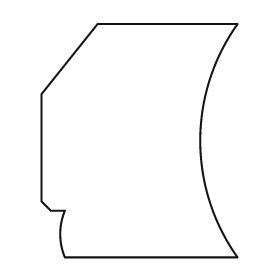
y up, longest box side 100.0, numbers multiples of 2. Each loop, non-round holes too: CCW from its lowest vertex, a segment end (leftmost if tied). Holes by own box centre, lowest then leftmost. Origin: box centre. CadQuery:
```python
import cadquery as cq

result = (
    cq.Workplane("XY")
    .moveTo(-32.0, -50.0)
    .lineTo(42.0, -50.0)
    .threePointArc((26.0, 0.0), (42.0, 50.0))
    .lineTo(-18.0, 50.0)
    .lineTo(-42.0, 20.0)
    .lineTo(-42.0, -26.0)
    .lineTo(-38.0, -30.0)
    .lineTo(-32.0, -30.0)
    .threePointArc((-34.0, -40.0), (-32.0, -50.0))
    .close()
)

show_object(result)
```